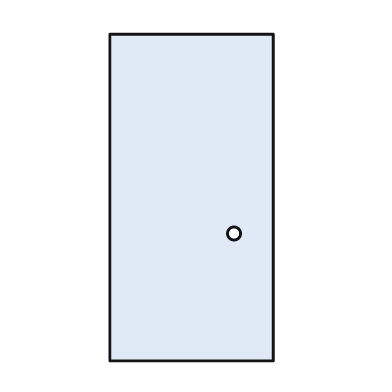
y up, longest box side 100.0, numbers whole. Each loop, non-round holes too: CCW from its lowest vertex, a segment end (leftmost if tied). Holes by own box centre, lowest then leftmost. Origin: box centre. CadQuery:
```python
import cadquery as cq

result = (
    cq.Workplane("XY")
    .moveTo(-25.0, -50.0)
    .lineTo(25.0, -50.0)
    .lineTo(25.0, 50.0)
    .lineTo(-25.0, 50.0)
    .close()
    .moveTo(13.0, -11.0)
    .circle(2.0)
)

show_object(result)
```